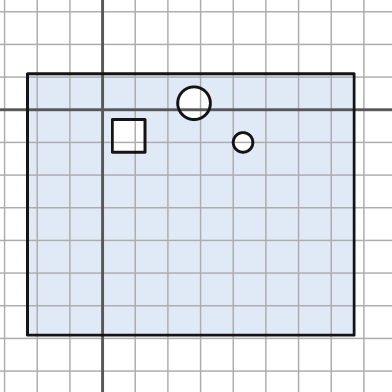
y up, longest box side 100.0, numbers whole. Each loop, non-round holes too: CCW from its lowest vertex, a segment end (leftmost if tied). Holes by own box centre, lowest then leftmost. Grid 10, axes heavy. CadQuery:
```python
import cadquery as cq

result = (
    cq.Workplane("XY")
    .moveTo(-23.0, -69.0)
    .lineTo(77.0, -69.0)
    .lineTo(77.0, 11.0)
    .lineTo(-23.0, 11.0)
    .close()
    .moveTo(43.0, -10.0)
    .circle(3.0)
    .moveTo(3.0, -13.0)
    .lineTo(13.0, -13.0)
    .lineTo(13.0, -3.0)
    .lineTo(3.0, -3.0)
    .close()
    .moveTo(28.0, 2.0)
    .circle(5.0)
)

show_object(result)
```